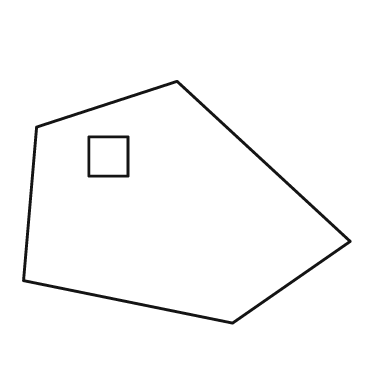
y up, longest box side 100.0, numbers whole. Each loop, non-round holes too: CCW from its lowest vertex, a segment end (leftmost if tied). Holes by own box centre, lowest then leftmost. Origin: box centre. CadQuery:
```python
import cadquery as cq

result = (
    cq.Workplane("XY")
    .moveTo(14.0, -37.0)
    .lineTo(50.0, -12.0)
    .lineTo(-3.0, 37.0)
    .lineTo(-46.0, 23.0)
    .lineTo(-50.0, -24.0)
    .close()
    .moveTo(-30.0, 8.0)
    .lineTo(-18.0, 8.0)
    .lineTo(-18.0, 20.0)
    .lineTo(-30.0, 20.0)
    .close()
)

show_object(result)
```